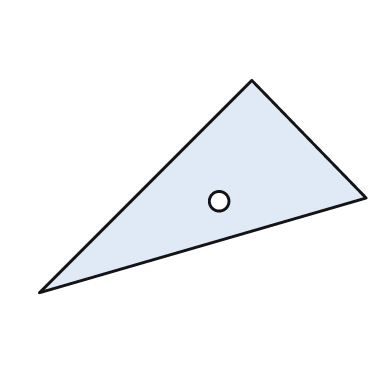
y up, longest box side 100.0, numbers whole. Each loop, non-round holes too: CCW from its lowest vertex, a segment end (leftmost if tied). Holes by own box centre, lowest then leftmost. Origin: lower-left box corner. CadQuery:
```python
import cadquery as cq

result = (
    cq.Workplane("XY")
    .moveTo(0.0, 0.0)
    .lineTo(100.0, 29.0)
    .lineTo(65.0, 65.0)
    .close()
    .moveTo(55.0, 28.0)
    .circle(3.0)
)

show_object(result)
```